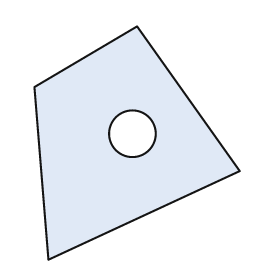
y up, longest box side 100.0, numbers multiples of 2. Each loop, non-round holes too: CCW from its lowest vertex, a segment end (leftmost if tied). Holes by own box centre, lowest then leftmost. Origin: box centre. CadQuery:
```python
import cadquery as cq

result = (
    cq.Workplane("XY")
    .moveTo(-38.0, -50.0)
    .lineTo(44.0, -12.0)
    .lineTo(0.0, 50.0)
    .lineTo(-44.0, 24.0)
    .close()
    .moveTo(-2.0, 4.0)
    .circle(10.0)
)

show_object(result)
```